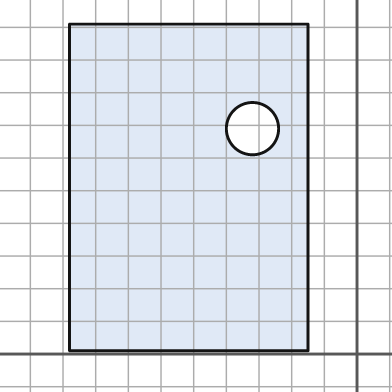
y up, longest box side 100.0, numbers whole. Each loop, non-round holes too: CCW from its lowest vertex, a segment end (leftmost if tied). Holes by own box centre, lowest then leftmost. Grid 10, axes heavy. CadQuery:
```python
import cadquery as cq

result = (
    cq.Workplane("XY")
    .moveTo(-88.0, 1.0)
    .lineTo(-15.0, 1.0)
    .lineTo(-15.0, 101.0)
    .lineTo(-88.0, 101.0)
    .close()
    .moveTo(-32.0, 69.0)
    .circle(8.0)
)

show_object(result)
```